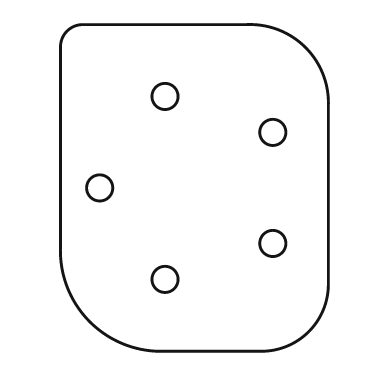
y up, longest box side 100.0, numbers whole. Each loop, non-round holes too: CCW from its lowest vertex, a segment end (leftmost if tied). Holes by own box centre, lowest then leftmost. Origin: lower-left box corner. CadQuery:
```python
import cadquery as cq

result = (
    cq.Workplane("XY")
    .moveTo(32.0, 0.0)
    .lineTo(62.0, 0.0)
    .threePointArc((76.0, 6.0), (82.0, 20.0))
    .lineTo(82.0, 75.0)
    .threePointArc((75.0, 93.0), (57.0, 100.0))
    .lineTo(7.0, 100.0)
    .threePointArc((2.0, 98.0), (0.0, 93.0))
    .lineTo(0.0, 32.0)
    .threePointArc((9.0, 9.0), (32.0, 0.0))
    .close()
    .moveTo(32.0, 22.0)
    .circle(4.0)
    .moveTo(65.0, 33.0)
    .circle(4.0)
    .moveTo(12.0, 50.0)
    .circle(4.0)
    .moveTo(65.0, 67.0)
    .circle(4.0)
    .moveTo(32.0, 78.0)
    .circle(4.0)
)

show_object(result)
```